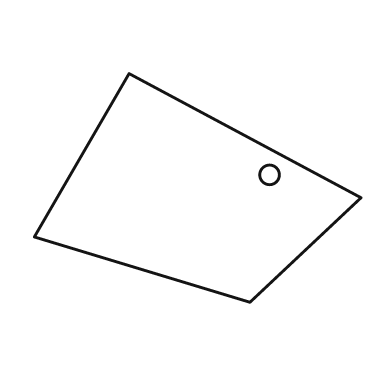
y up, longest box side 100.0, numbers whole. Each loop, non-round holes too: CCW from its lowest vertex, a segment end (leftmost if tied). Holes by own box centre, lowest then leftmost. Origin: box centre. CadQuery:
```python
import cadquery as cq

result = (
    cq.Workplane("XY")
    .moveTo(16.0, -35.0)
    .lineTo(50.0, -3.0)
    .lineTo(-21.0, 35.0)
    .lineTo(-50.0, -15.0)
    .close()
    .moveTo(22.0, 4.0)
    .circle(3.0)
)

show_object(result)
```